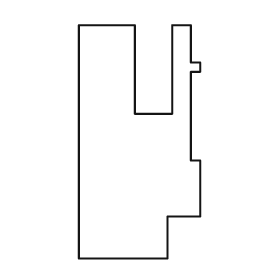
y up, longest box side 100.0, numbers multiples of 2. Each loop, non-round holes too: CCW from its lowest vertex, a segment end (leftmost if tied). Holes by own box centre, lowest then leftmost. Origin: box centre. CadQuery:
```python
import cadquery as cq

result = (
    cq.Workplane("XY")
    .moveTo(-26.0, -50.0)
    .lineTo(12.0, -50.0)
    .lineTo(12.0, -32.0)
    .lineTo(26.0, -32.0)
    .lineTo(26.0, -8.0)
    .lineTo(22.0, -8.0)
    .lineTo(22.0, 30.0)
    .lineTo(26.0, 30.0)
    .lineTo(26.0, 34.0)
    .lineTo(22.0, 34.0)
    .lineTo(22.0, 50.0)
    .lineTo(14.0, 50.0)
    .lineTo(14.0, 12.0)
    .lineTo(-2.0, 12.0)
    .lineTo(-2.0, 50.0)
    .lineTo(-26.0, 50.0)
    .close()
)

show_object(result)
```